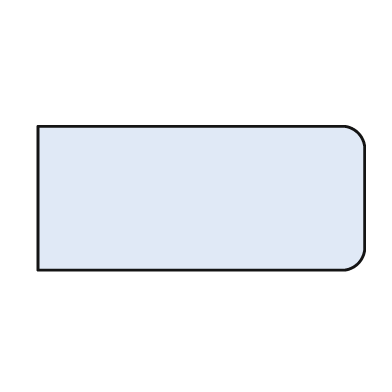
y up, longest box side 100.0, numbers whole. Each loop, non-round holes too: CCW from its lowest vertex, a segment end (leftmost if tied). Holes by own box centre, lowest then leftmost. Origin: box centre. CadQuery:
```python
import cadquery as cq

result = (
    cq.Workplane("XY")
    .moveTo(-50.0, -22.0)
    .lineTo(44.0, -22.0)
    .threePointArc((48.0, -20.0), (50.0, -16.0))
    .lineTo(50.0, 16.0)
    .threePointArc((48.0, 20.0), (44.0, 22.0))
    .lineTo(-50.0, 22.0)
    .close()
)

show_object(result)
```